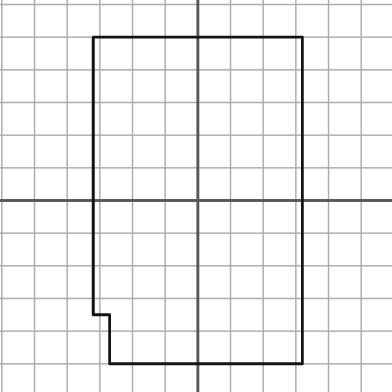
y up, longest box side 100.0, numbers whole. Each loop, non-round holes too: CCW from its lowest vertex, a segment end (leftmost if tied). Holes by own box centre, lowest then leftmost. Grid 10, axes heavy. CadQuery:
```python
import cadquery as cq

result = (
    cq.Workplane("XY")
    .moveTo(-27.0, -50.0)
    .lineTo(32.0, -50.0)
    .lineTo(32.0, 50.0)
    .lineTo(-32.0, 50.0)
    .lineTo(-32.0, -35.0)
    .lineTo(-27.0, -35.0)
    .close()
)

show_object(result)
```